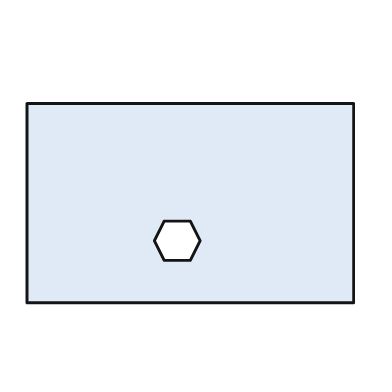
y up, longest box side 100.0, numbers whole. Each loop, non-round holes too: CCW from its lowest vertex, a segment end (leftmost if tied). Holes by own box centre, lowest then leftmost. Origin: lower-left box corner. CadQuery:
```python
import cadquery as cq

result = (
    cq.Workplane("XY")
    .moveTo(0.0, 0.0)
    .lineTo(100.0, 0.0)
    .lineTo(100.0, 61.0)
    .lineTo(0.0, 61.0)
    .close()
    .moveTo(42.0, 13.0)
    .lineTo(50.0, 13.0)
    .lineTo(53.0, 19.0)
    .lineTo(50.0, 25.0)
    .lineTo(42.0, 25.0)
    .lineTo(39.0, 19.0)
    .close()
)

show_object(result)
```